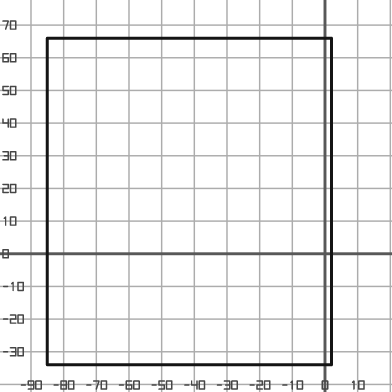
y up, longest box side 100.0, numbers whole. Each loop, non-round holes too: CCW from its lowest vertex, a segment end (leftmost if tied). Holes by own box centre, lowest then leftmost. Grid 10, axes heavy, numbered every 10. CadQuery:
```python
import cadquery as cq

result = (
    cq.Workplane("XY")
    .moveTo(-85.0, -34.0)
    .lineTo(2.0, -34.0)
    .lineTo(2.0, 66.0)
    .lineTo(-85.0, 66.0)
    .close()
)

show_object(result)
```